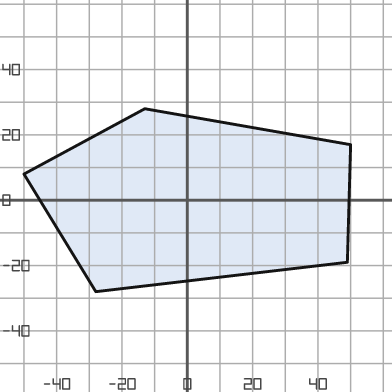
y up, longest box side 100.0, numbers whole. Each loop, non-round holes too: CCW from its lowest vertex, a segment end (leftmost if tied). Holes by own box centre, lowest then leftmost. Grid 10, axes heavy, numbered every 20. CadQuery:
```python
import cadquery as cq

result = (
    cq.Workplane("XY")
    .moveTo(-28.0, -28.0)
    .lineTo(49.0, -19.0)
    .lineTo(50.0, 17.0)
    .lineTo(-13.0, 28.0)
    .lineTo(-50.0, 8.0)
    .close()
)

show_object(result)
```